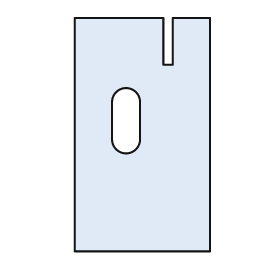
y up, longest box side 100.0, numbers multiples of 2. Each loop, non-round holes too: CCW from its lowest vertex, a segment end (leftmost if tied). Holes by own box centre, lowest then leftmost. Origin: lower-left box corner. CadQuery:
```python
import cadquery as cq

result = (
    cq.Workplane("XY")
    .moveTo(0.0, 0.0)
    .lineTo(58.0, 0.0)
    .lineTo(58.0, 100.0)
    .lineTo(42.0, 100.0)
    .lineTo(42.0, 80.0)
    .lineTo(38.0, 80.0)
    .lineTo(38.0, 100.0)
    .lineTo(0.0, 100.0)
    .close()
    .moveTo(16.0, 48.0)
    .threePointArc((22.0, 42.0), (28.0, 48.0))
    .lineTo(28.0, 64.0)
    .threePointArc((22.0, 70.0), (16.0, 64.0))
    .close()
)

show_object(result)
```